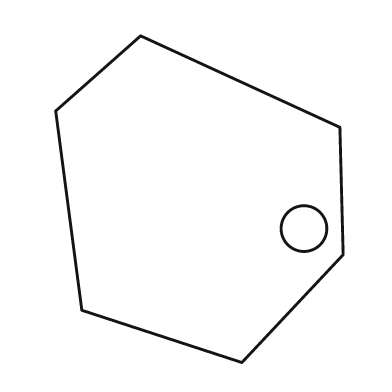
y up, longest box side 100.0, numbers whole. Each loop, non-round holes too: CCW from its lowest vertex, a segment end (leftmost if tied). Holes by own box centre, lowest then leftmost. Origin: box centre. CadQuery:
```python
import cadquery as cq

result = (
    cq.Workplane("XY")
    .moveTo(13.0, -50.0)
    .lineTo(44.0, -17.0)
    .lineTo(43.0, 22.0)
    .lineTo(-18.0, 50.0)
    .lineTo(-44.0, 27.0)
    .lineTo(-36.0, -34.0)
    .close()
    .moveTo(32.0, -9.0)
    .circle(7.0)
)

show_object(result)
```